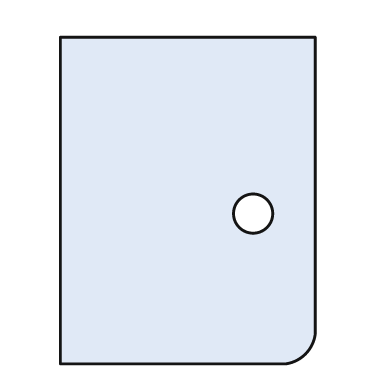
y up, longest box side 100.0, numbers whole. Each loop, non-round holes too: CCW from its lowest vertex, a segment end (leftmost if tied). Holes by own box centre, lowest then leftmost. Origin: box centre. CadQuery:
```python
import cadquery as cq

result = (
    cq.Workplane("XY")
    .moveTo(-39.0, -50.0)
    .lineTo(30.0, -50.0)
    .threePointArc((36.0, -47.0), (39.0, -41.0))
    .lineTo(39.0, 50.0)
    .lineTo(-39.0, 50.0)
    .close()
    .moveTo(20.0, -4.0)
    .circle(6.0)
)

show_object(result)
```